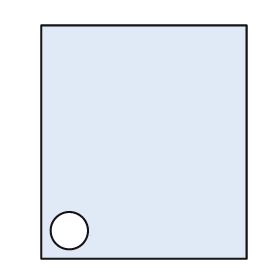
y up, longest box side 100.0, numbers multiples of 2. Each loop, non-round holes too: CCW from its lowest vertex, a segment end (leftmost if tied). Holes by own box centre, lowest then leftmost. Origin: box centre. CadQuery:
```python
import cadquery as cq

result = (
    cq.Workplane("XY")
    .moveTo(-44.0, -50.0)
    .lineTo(44.0, -50.0)
    .lineTo(44.0, 50.0)
    .lineTo(-44.0, 50.0)
    .close()
    .moveTo(-32.0, -38.0)
    .circle(8.0)
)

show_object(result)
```